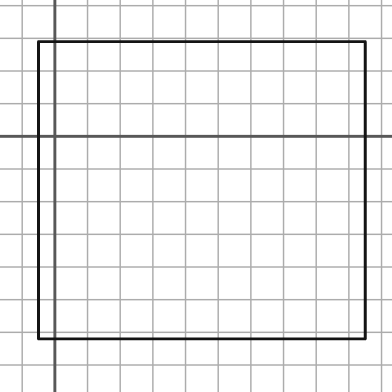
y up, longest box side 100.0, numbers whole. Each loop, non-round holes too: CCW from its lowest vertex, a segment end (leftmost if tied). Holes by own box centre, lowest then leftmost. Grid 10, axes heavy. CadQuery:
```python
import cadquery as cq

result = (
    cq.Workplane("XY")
    .moveTo(-5.0, -62.0)
    .lineTo(95.0, -62.0)
    .lineTo(95.0, 29.0)
    .lineTo(-5.0, 29.0)
    .close()
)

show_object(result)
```